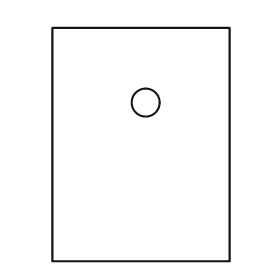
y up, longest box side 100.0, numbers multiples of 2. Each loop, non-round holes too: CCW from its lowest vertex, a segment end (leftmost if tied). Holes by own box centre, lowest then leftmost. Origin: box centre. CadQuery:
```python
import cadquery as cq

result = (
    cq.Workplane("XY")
    .moveTo(-38.0, -50.0)
    .lineTo(38.0, -50.0)
    .lineTo(38.0, 50.0)
    .lineTo(-38.0, 50.0)
    .close()
    .moveTo(2.0, 18.0)
    .circle(6.0)
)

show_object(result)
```